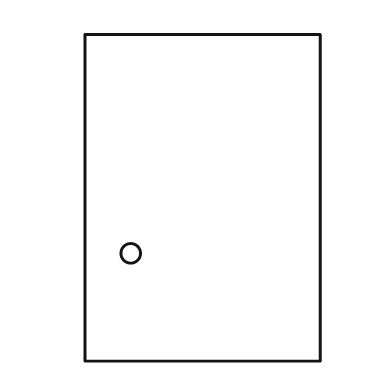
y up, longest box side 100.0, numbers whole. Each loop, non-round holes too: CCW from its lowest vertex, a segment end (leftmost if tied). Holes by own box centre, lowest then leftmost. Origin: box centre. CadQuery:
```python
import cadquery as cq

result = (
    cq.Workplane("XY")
    .moveTo(-36.0, -50.0)
    .lineTo(36.0, -50.0)
    .lineTo(36.0, 50.0)
    .lineTo(-36.0, 50.0)
    .close()
    .moveTo(-22.0, -17.0)
    .circle(3.0)
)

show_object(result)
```